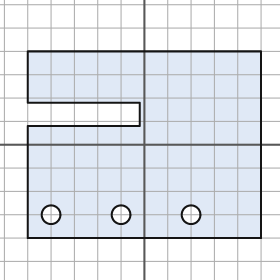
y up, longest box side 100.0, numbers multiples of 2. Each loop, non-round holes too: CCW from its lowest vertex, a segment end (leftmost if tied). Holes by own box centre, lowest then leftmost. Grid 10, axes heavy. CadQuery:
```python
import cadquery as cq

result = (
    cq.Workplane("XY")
    .moveTo(-50.0, -40.0)
    .lineTo(50.0, -40.0)
    .lineTo(50.0, 40.0)
    .lineTo(-50.0, 40.0)
    .lineTo(-50.0, 18.0)
    .lineTo(-2.0, 18.0)
    .lineTo(-2.0, 8.0)
    .lineTo(-50.0, 8.0)
    .close()
    .moveTo(-40.0, -30.0)
    .circle(4.0)
    .moveTo(-10.0, -30.0)
    .circle(4.0)
    .moveTo(20.0, -30.0)
    .circle(4.0)
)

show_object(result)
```